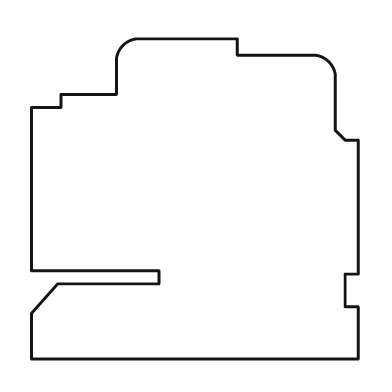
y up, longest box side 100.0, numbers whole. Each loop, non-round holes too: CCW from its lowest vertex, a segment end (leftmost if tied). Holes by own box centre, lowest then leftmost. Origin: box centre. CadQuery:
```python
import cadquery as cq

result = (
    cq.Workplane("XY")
    .moveTo(-50.0, -49.0)
    .lineTo(50.0, -49.0)
    .lineTo(50.0, -33.0)
    .lineTo(46.0, -33.0)
    .lineTo(46.0, -23.0)
    .lineTo(50.0, -23.0)
    .lineTo(50.0, 18.0)
    .lineTo(46.0, 18.0)
    .lineTo(43.0, 21.0)
    .lineTo(43.0, 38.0)
    .threePointArc((41.0, 42.0), (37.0, 44.0))
    .lineTo(13.0, 44.0)
    .lineTo(13.0, 49.0)
    .lineTo(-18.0, 49.0)
    .threePointArc((-22.0, 47.0), (-24.0, 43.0))
    .lineTo(-24.0, 32.0)
    .lineTo(-41.0, 32.0)
    .lineTo(-41.0, 28.0)
    .lineTo(-50.0, 28.0)
    .lineTo(-50.0, -22.0)
    .lineTo(-11.0, -22.0)
    .lineTo(-11.0, -26.0)
    .lineTo(-42.0, -26.0)
    .lineTo(-50.0, -35.0)
    .close()
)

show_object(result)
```